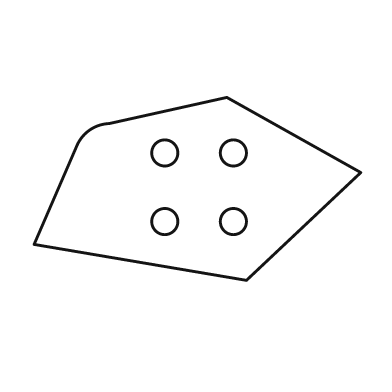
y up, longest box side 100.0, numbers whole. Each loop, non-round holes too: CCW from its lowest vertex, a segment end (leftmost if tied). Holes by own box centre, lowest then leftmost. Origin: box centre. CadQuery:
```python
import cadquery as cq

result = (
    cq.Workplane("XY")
    .moveTo(15.0, -28.0)
    .lineTo(50.0, 5.0)
    .lineTo(9.0, 28.0)
    .lineTo(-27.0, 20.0)
    .threePointArc((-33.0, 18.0), (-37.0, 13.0))
    .lineTo(-50.0, -17.0)
    .close()
    .moveTo(-10.0, -10.0)
    .circle(4.0)
    .moveTo(11.0, -10.0)
    .circle(4.0)
    .moveTo(-10.0, 11.0)
    .circle(4.0)
    .moveTo(11.0, 11.0)
    .circle(4.0)
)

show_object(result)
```